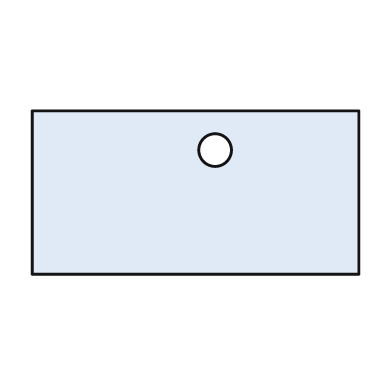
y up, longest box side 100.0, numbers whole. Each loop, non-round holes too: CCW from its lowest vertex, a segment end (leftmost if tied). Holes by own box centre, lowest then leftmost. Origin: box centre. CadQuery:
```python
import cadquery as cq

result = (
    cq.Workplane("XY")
    .moveTo(-50.0, -25.0)
    .lineTo(50.0, -25.0)
    .lineTo(50.0, 25.0)
    .lineTo(-50.0, 25.0)
    .close()
    .moveTo(6.0, 13.0)
    .circle(5.0)
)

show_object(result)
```